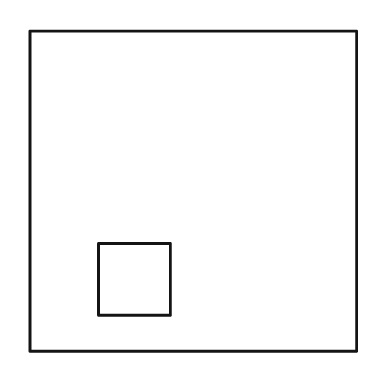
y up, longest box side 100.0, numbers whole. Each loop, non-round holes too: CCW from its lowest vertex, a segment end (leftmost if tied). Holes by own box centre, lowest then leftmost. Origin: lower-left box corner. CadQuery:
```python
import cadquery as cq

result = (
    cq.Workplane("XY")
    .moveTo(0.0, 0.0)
    .lineTo(100.0, 0.0)
    .lineTo(100.0, 98.0)
    .lineTo(0.0, 98.0)
    .close()
    .moveTo(21.0, 11.0)
    .lineTo(43.0, 11.0)
    .lineTo(43.0, 33.0)
    .lineTo(21.0, 33.0)
    .close()
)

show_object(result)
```